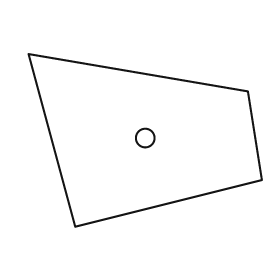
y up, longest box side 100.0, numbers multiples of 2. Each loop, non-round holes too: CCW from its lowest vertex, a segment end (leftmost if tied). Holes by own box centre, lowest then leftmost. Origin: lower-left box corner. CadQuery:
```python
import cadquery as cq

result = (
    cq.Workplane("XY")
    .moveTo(20.0, 0.0)
    .lineTo(100.0, 20.0)
    .lineTo(94.0, 58.0)
    .lineTo(0.0, 74.0)
    .close()
    .moveTo(50.0, 38.0)
    .circle(4.0)
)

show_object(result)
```